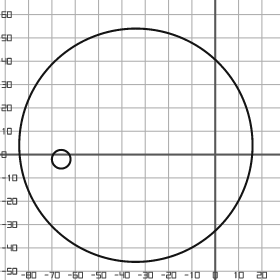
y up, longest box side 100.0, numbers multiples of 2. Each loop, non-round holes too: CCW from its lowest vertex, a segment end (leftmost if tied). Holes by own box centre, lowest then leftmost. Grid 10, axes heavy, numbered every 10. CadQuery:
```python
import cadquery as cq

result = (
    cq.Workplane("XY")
    .moveTo(-34.0, 4.0)
    .circle(50.0)
    .moveTo(-66.0, -2.0)
    .circle(4.0)
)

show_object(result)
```